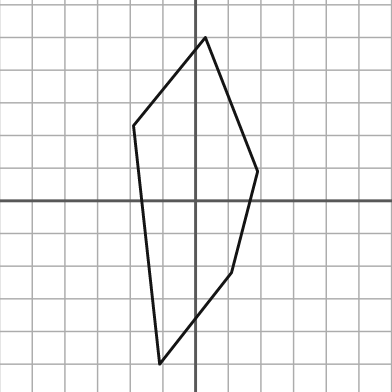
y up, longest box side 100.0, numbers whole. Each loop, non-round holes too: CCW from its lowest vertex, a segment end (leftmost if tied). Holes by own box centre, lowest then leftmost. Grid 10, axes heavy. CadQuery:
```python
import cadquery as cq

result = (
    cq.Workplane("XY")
    .moveTo(-11.0, -50.0)
    .lineTo(11.0, -22.0)
    .lineTo(19.0, 9.0)
    .lineTo(3.0, 50.0)
    .lineTo(-19.0, 23.0)
    .close()
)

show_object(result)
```